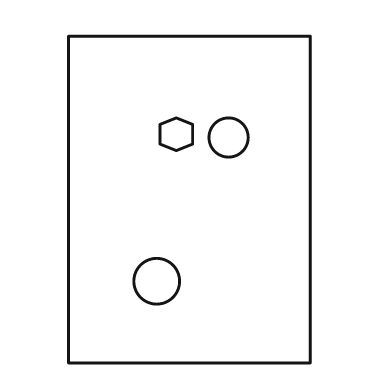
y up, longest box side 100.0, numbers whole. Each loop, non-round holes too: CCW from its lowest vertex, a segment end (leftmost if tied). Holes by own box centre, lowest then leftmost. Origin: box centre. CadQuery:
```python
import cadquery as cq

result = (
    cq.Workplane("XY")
    .moveTo(-37.0, -50.0)
    .lineTo(37.0, -50.0)
    .lineTo(37.0, 50.0)
    .lineTo(-37.0, 50.0)
    .close()
    .moveTo(-10.0, -25.0)
    .circle(7.0)
    .moveTo(12.0, 19.0)
    .circle(6.0)
    .moveTo(-4.0, 15.0)
    .lineTo(1.0, 17.0)
    .lineTo(1.0, 23.0)
    .lineTo(-4.0, 25.0)
    .lineTo(-9.0, 23.0)
    .lineTo(-9.0, 17.0)
    .close()
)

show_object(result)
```